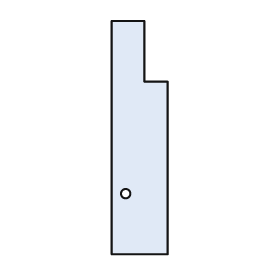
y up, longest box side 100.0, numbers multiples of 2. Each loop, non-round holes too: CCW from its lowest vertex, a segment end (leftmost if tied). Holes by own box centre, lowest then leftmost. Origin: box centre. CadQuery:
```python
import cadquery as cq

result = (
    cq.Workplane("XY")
    .moveTo(-12.0, -50.0)
    .lineTo(12.0, -50.0)
    .lineTo(12.0, 24.0)
    .lineTo(2.0, 24.0)
    .lineTo(2.0, 50.0)
    .lineTo(-12.0, 50.0)
    .close()
    .moveTo(-6.0, -24.0)
    .circle(2.0)
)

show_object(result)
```